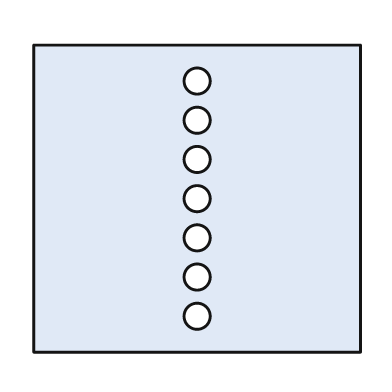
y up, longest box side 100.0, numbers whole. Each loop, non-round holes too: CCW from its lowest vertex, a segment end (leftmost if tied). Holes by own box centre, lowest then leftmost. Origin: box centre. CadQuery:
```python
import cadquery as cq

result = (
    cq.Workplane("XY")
    .moveTo(-50.0, -47.0)
    .lineTo(50.0, -47.0)
    .lineTo(50.0, 47.0)
    .lineTo(-50.0, 47.0)
    .close()
    .moveTo(0.0, -36.0)
    .circle(4.0)
    .moveTo(0.0, -24.0)
    .circle(4.0)
    .moveTo(0.0, -12.0)
    .circle(4.0)
    .moveTo(0.0, 0.0)
    .circle(4.0)
    .moveTo(0.0, 12.0)
    .circle(4.0)
    .moveTo(0.0, 24.0)
    .circle(4.0)
    .moveTo(0.0, 36.0)
    .circle(4.0)
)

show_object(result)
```